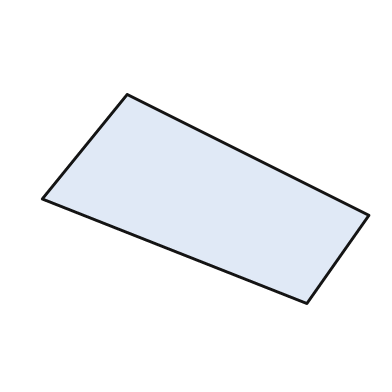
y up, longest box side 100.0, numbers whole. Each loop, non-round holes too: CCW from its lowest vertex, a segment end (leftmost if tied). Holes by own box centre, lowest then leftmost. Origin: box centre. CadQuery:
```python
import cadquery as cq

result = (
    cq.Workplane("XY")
    .moveTo(31.0, -32.0)
    .lineTo(50.0, -5.0)
    .lineTo(-24.0, 32.0)
    .lineTo(-50.0, 0.0)
    .close()
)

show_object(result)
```